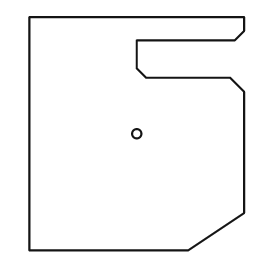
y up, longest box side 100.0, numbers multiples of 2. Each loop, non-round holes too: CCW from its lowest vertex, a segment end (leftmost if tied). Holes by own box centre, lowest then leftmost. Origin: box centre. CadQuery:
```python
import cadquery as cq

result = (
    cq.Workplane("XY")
    .moveTo(-46.0, -50.0)
    .lineTo(22.0, -50.0)
    .lineTo(46.0, -34.0)
    .lineTo(46.0, 18.0)
    .lineTo(40.0, 24.0)
    .lineTo(4.0, 24.0)
    .lineTo(0.0, 28.0)
    .lineTo(0.0, 40.0)
    .lineTo(42.0, 40.0)
    .lineTo(46.0, 44.0)
    .lineTo(46.0, 50.0)
    .lineTo(-46.0, 50.0)
    .close()
    .moveTo(0.0, 0.0)
    .circle(2.0)
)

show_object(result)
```